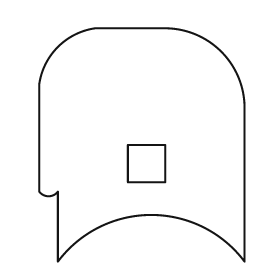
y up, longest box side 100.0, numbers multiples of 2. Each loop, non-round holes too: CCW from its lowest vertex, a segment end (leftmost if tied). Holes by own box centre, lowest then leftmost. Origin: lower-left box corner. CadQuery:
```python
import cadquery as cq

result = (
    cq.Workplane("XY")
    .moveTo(8.0, 0.0)
    .threePointArc((48.0, 20.0), (88.0, 0.0))
    .lineTo(88.0, 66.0)
    .threePointArc((78.0, 90.0), (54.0, 100.0))
    .lineTo(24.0, 100.0)
    .threePointArc((8.0, 92.0), (0.0, 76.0))
    .lineTo(0.0, 30.0)
    .threePointArc((4.0, 28.0), (8.0, 30.0))
    .close()
    .moveTo(38.0, 34.0)
    .lineTo(54.0, 34.0)
    .lineTo(54.0, 50.0)
    .lineTo(38.0, 50.0)
    .close()
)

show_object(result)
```